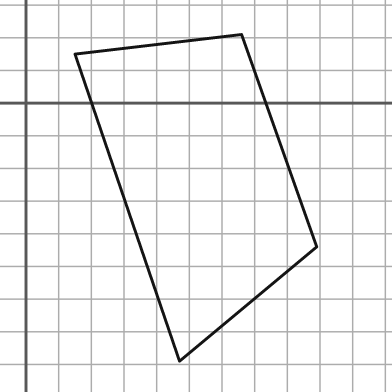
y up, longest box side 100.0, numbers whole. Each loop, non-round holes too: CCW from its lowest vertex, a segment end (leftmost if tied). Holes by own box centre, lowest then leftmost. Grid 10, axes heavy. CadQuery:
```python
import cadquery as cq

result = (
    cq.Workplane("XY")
    .moveTo(47.0, -79.0)
    .lineTo(89.0, -44.0)
    .lineTo(66.0, 21.0)
    .lineTo(15.0, 15.0)
    .close()
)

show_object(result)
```